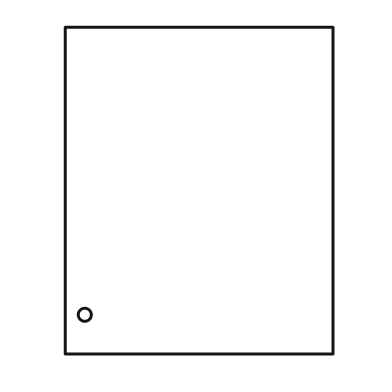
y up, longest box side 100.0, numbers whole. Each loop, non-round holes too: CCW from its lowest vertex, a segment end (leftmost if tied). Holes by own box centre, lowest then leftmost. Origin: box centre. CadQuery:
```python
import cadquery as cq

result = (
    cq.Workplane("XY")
    .moveTo(-41.0, -50.0)
    .lineTo(41.0, -50.0)
    .lineTo(41.0, 50.0)
    .lineTo(-41.0, 50.0)
    .close()
    .moveTo(-35.0, -38.0)
    .circle(2.0)
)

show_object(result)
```